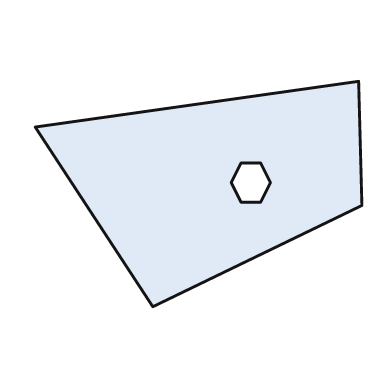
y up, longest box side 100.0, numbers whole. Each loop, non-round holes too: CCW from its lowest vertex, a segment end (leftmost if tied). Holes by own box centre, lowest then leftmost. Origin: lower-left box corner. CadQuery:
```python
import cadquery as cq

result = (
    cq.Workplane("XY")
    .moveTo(36.0, 0.0)
    .lineTo(100.0, 31.0)
    .lineTo(99.0, 69.0)
    .lineTo(0.0, 55.0)
    .close()
    .moveTo(63.0, 32.0)
    .lineTo(69.0, 32.0)
    .lineTo(72.0, 38.0)
    .lineTo(69.0, 44.0)
    .lineTo(63.0, 44.0)
    .lineTo(60.0, 38.0)
    .close()
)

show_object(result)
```